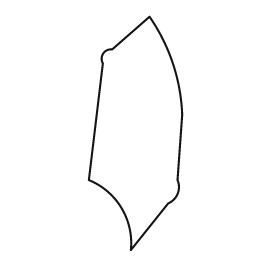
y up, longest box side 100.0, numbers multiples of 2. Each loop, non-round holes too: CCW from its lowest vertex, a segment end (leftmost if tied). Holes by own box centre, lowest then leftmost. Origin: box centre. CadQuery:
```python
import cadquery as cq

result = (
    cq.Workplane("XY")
    .moveTo(-2.0, -50.0)
    .lineTo(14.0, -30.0)
    .threePointArc((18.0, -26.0), (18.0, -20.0))
    .lineTo(20.0, 8.0)
    .threePointArc((16.0, 30.0), (6.0, 50.0))
    .lineTo(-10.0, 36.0)
    .threePointArc((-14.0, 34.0), (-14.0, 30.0))
    .lineTo(-20.0, -20.0)
    .threePointArc((-6.0, -32.0), (-2.0, -50.0))
    .close()
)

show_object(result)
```